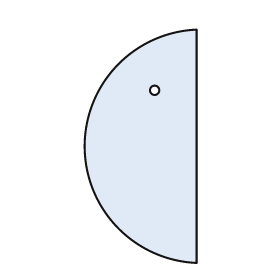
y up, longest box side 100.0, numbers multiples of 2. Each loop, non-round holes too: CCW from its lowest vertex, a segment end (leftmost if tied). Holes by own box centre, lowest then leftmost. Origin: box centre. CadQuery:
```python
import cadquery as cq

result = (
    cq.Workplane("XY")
    .moveTo(24.0, -50.0)
    .lineTo(24.0, 50.0)
    .threePointArc((-24.0, 0.0), (24.0, -50.0))
    .close()
    .moveTo(6.0, 24.0)
    .circle(2.0)
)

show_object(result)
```